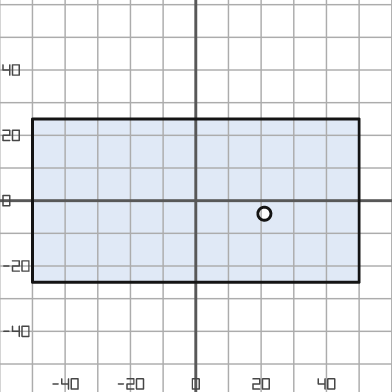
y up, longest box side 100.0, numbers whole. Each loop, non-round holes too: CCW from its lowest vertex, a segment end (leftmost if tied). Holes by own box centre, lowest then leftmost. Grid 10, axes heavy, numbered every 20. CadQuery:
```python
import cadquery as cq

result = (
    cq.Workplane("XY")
    .moveTo(-50.0, -25.0)
    .lineTo(50.0, -25.0)
    .lineTo(50.0, 25.0)
    .lineTo(-50.0, 25.0)
    .close()
    .moveTo(21.0, -4.0)
    .circle(2.0)
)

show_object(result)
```